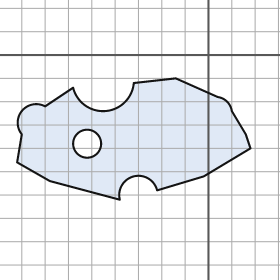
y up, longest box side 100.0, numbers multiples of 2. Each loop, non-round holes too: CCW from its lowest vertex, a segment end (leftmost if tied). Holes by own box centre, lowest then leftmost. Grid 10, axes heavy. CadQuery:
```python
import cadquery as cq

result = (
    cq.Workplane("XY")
    .moveTo(-38.0, -62.0)
    .threePointArc((-32.0, -52.0), (-22.0, -58.0))
    .lineTo(-2.0, -52.0)
    .lineTo(18.0, -40.0)
    .lineTo(16.0, -34.0)
    .lineTo(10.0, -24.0)
    .threePointArc((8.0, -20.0), (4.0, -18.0))
    .lineTo(-14.0, -10.0)
    .lineTo(-32.0, -12.0)
    .threePointArc((-44.0, -24.0), (-58.0, -14.0))
    .lineTo(-70.0, -22.0)
    .threePointArc((-80.0, -24.0), (-80.0, -34.0))
    .lineTo(-82.0, -46.0)
    .lineTo(-68.0, -54.0)
    .close()
    .moveTo(-52.0, -38.0)
    .circle(6.0)
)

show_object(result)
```